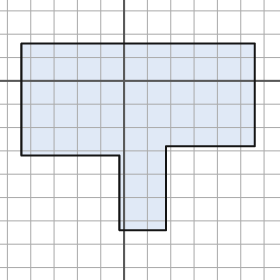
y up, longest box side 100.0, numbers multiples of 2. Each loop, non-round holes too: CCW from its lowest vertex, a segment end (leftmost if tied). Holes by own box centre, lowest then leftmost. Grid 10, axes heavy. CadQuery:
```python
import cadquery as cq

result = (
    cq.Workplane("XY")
    .moveTo(-2.0, -64.0)
    .lineTo(18.0, -64.0)
    .lineTo(18.0, -28.0)
    .lineTo(56.0, -28.0)
    .lineTo(56.0, 16.0)
    .lineTo(-44.0, 16.0)
    .lineTo(-44.0, -32.0)
    .lineTo(-2.0, -32.0)
    .close()
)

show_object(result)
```